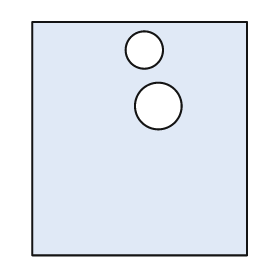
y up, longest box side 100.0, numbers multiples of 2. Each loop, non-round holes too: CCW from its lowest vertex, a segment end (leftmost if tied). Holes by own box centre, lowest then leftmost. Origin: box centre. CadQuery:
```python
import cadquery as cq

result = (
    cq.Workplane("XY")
    .moveTo(-46.0, -50.0)
    .lineTo(46.0, -50.0)
    .lineTo(46.0, 50.0)
    .lineTo(-46.0, 50.0)
    .close()
    .moveTo(8.0, 14.0)
    .circle(10.0)
    .moveTo(2.0, 38.0)
    .circle(8.0)
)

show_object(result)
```